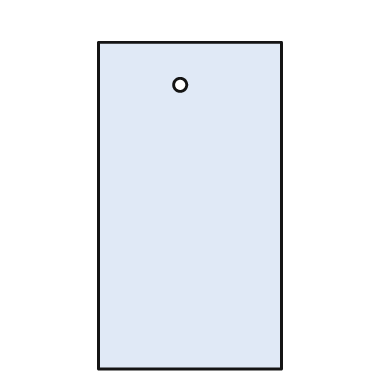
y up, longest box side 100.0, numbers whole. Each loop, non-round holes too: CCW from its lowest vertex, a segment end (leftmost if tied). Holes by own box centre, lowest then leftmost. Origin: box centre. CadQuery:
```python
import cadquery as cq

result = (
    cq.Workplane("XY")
    .moveTo(-28.0, -50.0)
    .lineTo(28.0, -50.0)
    .lineTo(28.0, 50.0)
    .lineTo(-28.0, 50.0)
    .close()
    .moveTo(-3.0, 37.0)
    .circle(2.0)
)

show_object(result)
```